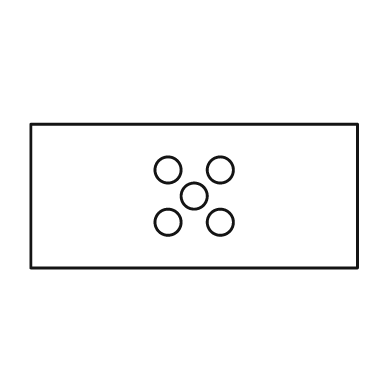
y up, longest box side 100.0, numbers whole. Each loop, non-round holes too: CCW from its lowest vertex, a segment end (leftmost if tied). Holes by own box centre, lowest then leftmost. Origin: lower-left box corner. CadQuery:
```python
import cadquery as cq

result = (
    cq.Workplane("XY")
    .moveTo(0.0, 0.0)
    .lineTo(100.0, 0.0)
    .lineTo(100.0, 44.0)
    .lineTo(0.0, 44.0)
    .close()
    .moveTo(42.0, 14.0)
    .circle(4.0)
    .moveTo(58.0, 14.0)
    .circle(4.0)
    .moveTo(50.0, 22.0)
    .circle(4.0)
    .moveTo(42.0, 30.0)
    .circle(4.0)
    .moveTo(58.0, 30.0)
    .circle(4.0)
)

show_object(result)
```